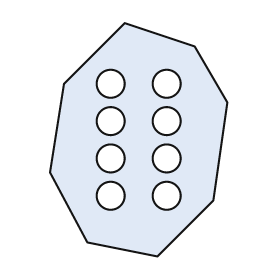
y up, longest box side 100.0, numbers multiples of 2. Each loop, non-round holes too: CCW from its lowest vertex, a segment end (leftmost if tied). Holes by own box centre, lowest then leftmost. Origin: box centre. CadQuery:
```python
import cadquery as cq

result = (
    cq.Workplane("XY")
    .moveTo(8.0, -50.0)
    .lineTo(32.0, -26.0)
    .lineTo(38.0, 16.0)
    .lineTo(24.0, 40.0)
    .lineTo(-6.0, 50.0)
    .lineTo(-32.0, 24.0)
    .lineTo(-38.0, -14.0)
    .lineTo(-22.0, -44.0)
    .close()
    .moveTo(-12.0, -24.0)
    .circle(6.0)
    .moveTo(12.0, -24.0)
    .circle(6.0)
    .moveTo(-12.0, -8.0)
    .circle(6.0)
    .moveTo(12.0, -8.0)
    .circle(6.0)
    .moveTo(-12.0, 8.0)
    .circle(6.0)
    .moveTo(12.0, 8.0)
    .circle(6.0)
    .moveTo(-12.0, 24.0)
    .circle(6.0)
    .moveTo(12.0, 24.0)
    .circle(6.0)
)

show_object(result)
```